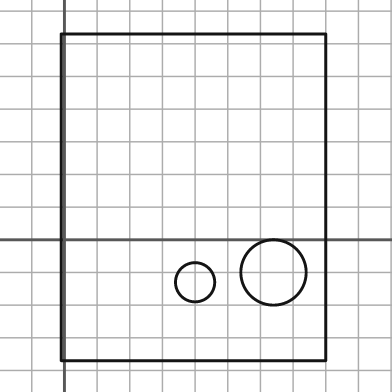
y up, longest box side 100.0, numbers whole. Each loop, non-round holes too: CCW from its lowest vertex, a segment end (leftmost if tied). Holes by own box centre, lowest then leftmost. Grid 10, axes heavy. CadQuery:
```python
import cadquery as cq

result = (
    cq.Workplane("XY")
    .moveTo(-1.0, -37.0)
    .lineTo(80.0, -37.0)
    .lineTo(80.0, 63.0)
    .lineTo(-1.0, 63.0)
    .close()
    .moveTo(40.0, -13.0)
    .circle(6.0)
    .moveTo(64.0, -10.0)
    .circle(10.0)
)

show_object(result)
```